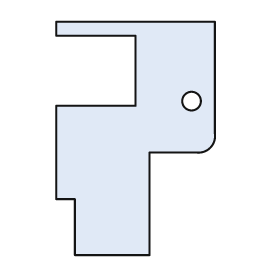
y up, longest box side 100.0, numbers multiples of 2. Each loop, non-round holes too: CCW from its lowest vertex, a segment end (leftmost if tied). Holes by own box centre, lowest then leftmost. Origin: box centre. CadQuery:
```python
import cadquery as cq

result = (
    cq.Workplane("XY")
    .moveTo(-26.0, -50.0)
    .lineTo(6.0, -50.0)
    .lineTo(6.0, -6.0)
    .lineTo(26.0, -6.0)
    .threePointArc((32.0, -4.0), (34.0, 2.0))
    .lineTo(34.0, 50.0)
    .lineTo(-34.0, 50.0)
    .lineTo(-34.0, 44.0)
    .lineTo(0.0, 44.0)
    .lineTo(0.0, 14.0)
    .lineTo(-34.0, 14.0)
    .lineTo(-34.0, -26.0)
    .lineTo(-26.0, -26.0)
    .close()
    .moveTo(24.0, 16.0)
    .circle(4.0)
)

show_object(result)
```